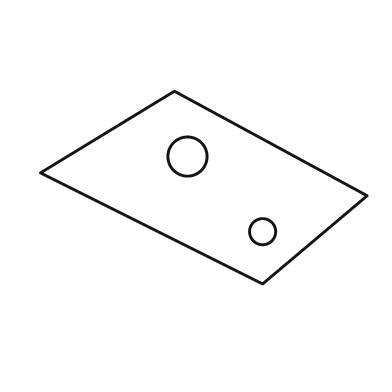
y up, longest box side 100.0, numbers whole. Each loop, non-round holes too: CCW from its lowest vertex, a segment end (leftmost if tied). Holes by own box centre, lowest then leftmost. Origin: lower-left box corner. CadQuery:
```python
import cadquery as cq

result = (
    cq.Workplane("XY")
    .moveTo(68.0, 0.0)
    .lineTo(100.0, 27.0)
    .lineTo(41.0, 59.0)
    .lineTo(0.0, 34.0)
    .close()
    .moveTo(68.0, 16.0)
    .circle(4.0)
    .moveTo(45.0, 39.0)
    .circle(6.0)
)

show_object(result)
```